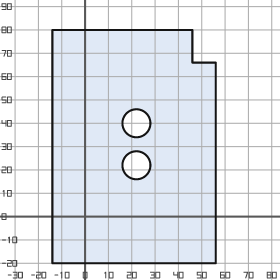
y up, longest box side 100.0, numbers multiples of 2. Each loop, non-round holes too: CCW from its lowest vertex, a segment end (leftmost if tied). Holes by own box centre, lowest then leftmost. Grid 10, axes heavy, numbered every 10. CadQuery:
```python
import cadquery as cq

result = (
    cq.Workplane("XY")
    .moveTo(-14.0, -20.0)
    .lineTo(56.0, -20.0)
    .lineTo(56.0, 66.0)
    .lineTo(46.0, 66.0)
    .lineTo(46.0, 80.0)
    .lineTo(-14.0, 80.0)
    .close()
    .moveTo(22.0, 22.0)
    .circle(6.0)
    .moveTo(22.0, 40.0)
    .circle(6.0)
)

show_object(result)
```